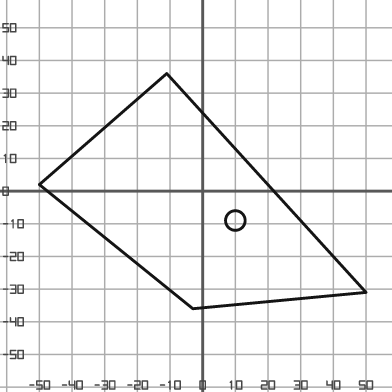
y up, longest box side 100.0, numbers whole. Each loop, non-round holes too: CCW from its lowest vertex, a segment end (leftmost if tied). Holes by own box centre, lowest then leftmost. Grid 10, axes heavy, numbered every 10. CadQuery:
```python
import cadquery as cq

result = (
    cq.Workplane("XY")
    .moveTo(-3.0, -36.0)
    .lineTo(50.0, -31.0)
    .lineTo(-11.0, 36.0)
    .lineTo(-50.0, 2.0)
    .close()
    .moveTo(10.0, -9.0)
    .circle(3.0)
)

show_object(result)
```